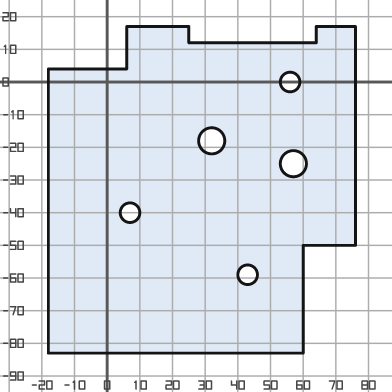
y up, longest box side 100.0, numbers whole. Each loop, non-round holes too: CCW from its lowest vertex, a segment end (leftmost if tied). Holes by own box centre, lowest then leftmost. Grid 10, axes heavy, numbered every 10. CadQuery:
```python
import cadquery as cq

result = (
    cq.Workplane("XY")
    .moveTo(-18.0, -83.0)
    .lineTo(60.0, -83.0)
    .lineTo(60.0, -50.0)
    .lineTo(76.0, -50.0)
    .lineTo(76.0, 17.0)
    .lineTo(64.0, 17.0)
    .lineTo(64.0, 12.0)
    .lineTo(25.0, 12.0)
    .lineTo(25.0, 17.0)
    .lineTo(6.0, 17.0)
    .lineTo(6.0, 4.0)
    .lineTo(-18.0, 4.0)
    .close()
    .moveTo(43.0, -59.0)
    .circle(3.0)
    .moveTo(7.0, -40.0)
    .circle(3.0)
    .moveTo(57.0, -25.0)
    .circle(4.0)
    .moveTo(32.0, -18.0)
    .circle(4.0)
    .moveTo(56.0, 0.0)
    .circle(3.0)
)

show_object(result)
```